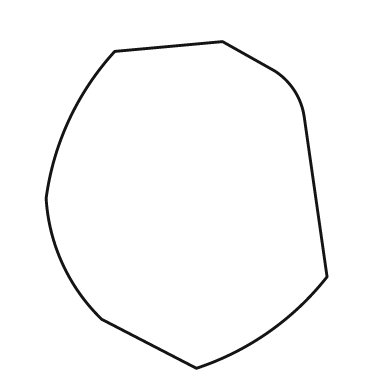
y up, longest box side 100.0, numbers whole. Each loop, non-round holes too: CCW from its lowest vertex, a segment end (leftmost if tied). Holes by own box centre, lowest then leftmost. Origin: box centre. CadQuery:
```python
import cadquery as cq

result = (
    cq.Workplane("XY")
    .moveTo(3.0, -50.0)
    .threePointArc((25.0, -39.0), (43.0, -22.0))
    .lineTo(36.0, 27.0)
    .threePointArc((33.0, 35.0), (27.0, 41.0))
    .lineTo(11.0, 50.0)
    .lineTo(-22.0, 47.0)
    .threePointArc((-36.0, 26.0), (-43.0, 2.0))
    .threePointArc((-38.0, -18.0), (-26.0, -35.0))
    .close()
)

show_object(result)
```